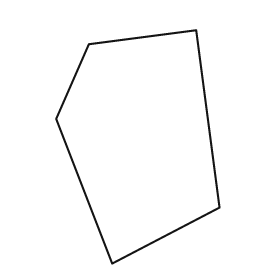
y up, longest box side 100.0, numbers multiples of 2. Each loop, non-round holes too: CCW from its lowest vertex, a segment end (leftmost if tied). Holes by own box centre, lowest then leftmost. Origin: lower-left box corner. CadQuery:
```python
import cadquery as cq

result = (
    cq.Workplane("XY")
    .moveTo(24.0, 0.0)
    .lineTo(70.0, 24.0)
    .lineTo(60.0, 100.0)
    .lineTo(14.0, 94.0)
    .lineTo(0.0, 62.0)
    .close()
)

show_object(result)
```